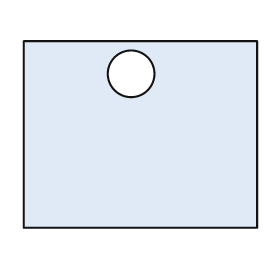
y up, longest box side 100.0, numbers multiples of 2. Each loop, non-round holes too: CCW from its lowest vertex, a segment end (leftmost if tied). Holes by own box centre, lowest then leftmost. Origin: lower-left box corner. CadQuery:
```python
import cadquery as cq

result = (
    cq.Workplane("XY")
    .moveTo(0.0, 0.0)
    .lineTo(100.0, 0.0)
    .lineTo(100.0, 80.0)
    .lineTo(0.0, 80.0)
    .close()
    .moveTo(46.0, 66.0)
    .circle(10.0)
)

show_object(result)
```